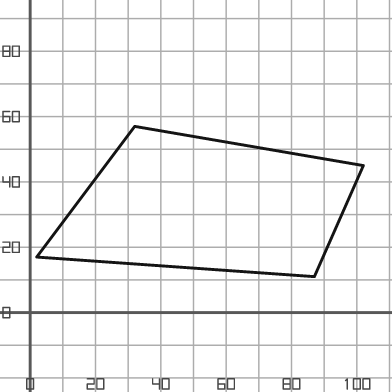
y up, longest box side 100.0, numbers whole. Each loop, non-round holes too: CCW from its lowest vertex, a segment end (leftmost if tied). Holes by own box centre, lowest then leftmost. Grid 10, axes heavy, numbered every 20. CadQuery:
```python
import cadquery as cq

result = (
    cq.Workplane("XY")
    .moveTo(87.0, 11.0)
    .lineTo(102.0, 45.0)
    .lineTo(32.0, 57.0)
    .lineTo(2.0, 17.0)
    .close()
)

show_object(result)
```